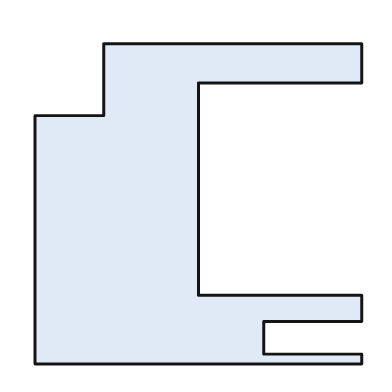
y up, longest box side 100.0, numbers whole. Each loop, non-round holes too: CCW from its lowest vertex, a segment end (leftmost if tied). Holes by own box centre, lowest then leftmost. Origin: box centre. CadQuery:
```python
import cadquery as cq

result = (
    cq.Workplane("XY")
    .moveTo(-50.0, -49.0)
    .lineTo(50.0, -49.0)
    .lineTo(50.0, -46.0)
    .lineTo(20.0, -46.0)
    .lineTo(20.0, -36.0)
    .lineTo(50.0, -36.0)
    .lineTo(50.0, -28.0)
    .lineTo(0.0, -28.0)
    .lineTo(0.0, 37.0)
    .lineTo(50.0, 37.0)
    .lineTo(50.0, 49.0)
    .lineTo(-29.0, 49.0)
    .lineTo(-29.0, 27.0)
    .lineTo(-50.0, 27.0)
    .close()
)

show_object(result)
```